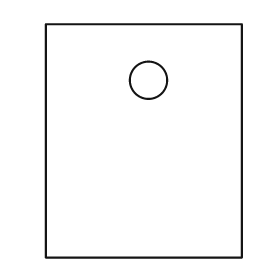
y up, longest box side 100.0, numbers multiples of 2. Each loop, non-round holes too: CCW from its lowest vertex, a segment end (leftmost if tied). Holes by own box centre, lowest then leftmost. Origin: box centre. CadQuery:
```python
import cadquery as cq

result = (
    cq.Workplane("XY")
    .moveTo(-42.0, -50.0)
    .lineTo(42.0, -50.0)
    .lineTo(42.0, 50.0)
    .lineTo(-42.0, 50.0)
    .close()
    .moveTo(2.0, 26.0)
    .circle(8.0)
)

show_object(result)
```